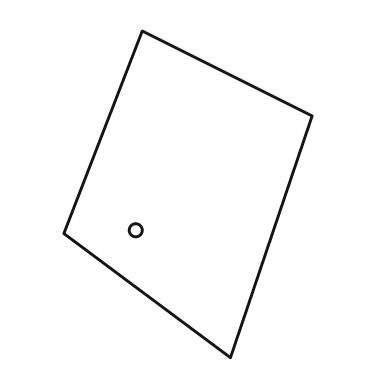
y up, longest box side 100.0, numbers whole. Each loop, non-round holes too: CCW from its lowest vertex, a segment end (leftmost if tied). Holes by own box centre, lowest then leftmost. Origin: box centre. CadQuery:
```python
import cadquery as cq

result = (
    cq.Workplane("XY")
    .moveTo(13.0, -50.0)
    .lineTo(38.0, 24.0)
    .lineTo(-14.0, 50.0)
    .lineTo(-38.0, -12.0)
    .close()
    .moveTo(-16.0, -11.0)
    .circle(2.0)
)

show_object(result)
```